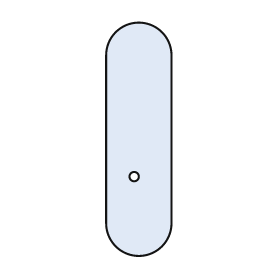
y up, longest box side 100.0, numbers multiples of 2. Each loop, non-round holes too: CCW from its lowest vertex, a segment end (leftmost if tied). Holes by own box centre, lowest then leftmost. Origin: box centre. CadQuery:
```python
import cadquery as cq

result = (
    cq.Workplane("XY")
    .moveTo(-14.0, -36.0)
    .threePointArc((0.0, -50.0), (14.0, -36.0))
    .lineTo(14.0, 36.0)
    .threePointArc((0.0, 50.0), (-14.0, 36.0))
    .close()
    .moveTo(-2.0, -16.0)
    .circle(2.0)
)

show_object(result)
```